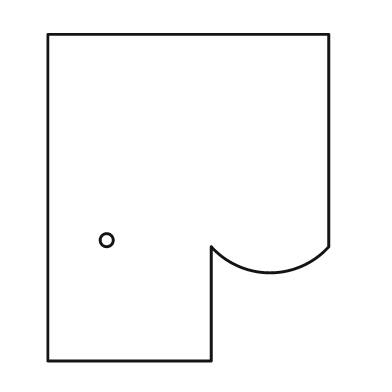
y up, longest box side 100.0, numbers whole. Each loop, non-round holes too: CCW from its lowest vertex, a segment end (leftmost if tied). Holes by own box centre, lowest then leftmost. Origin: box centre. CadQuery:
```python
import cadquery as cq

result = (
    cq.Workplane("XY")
    .moveTo(-43.0, -50.0)
    .lineTo(7.0, -50.0)
    .lineTo(7.0, -15.0)
    .threePointArc((25.0, -23.0), (43.0, -15.0))
    .lineTo(43.0, 50.0)
    .lineTo(-43.0, 50.0)
    .close()
    .moveTo(-25.0, -13.0)
    .circle(2.0)
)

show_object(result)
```